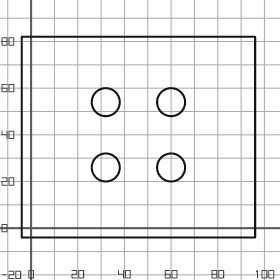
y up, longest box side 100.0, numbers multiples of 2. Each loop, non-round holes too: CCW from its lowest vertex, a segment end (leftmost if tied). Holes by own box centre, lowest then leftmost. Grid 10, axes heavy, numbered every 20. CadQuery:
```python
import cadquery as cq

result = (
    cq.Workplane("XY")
    .moveTo(-4.0, -4.0)
    .lineTo(96.0, -4.0)
    .lineTo(96.0, 82.0)
    .lineTo(-4.0, 82.0)
    .close()
    .moveTo(32.0, 26.0)
    .circle(6.0)
    .moveTo(60.0, 26.0)
    .circle(6.0)
    .moveTo(32.0, 54.0)
    .circle(6.0)
    .moveTo(60.0, 54.0)
    .circle(6.0)
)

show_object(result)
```